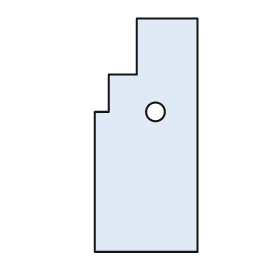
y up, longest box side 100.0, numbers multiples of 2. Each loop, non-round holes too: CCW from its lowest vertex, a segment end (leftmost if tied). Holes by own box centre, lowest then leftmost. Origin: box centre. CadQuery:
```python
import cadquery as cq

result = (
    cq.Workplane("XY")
    .moveTo(-22.0, -50.0)
    .lineTo(22.0, -50.0)
    .lineTo(22.0, 50.0)
    .lineTo(-4.0, 50.0)
    .lineTo(-4.0, 26.0)
    .lineTo(-16.0, 26.0)
    .lineTo(-16.0, 10.0)
    .lineTo(-22.0, 10.0)
    .close()
    .moveTo(4.0, 10.0)
    .circle(4.0)
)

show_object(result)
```